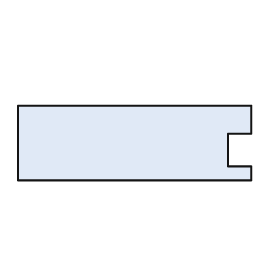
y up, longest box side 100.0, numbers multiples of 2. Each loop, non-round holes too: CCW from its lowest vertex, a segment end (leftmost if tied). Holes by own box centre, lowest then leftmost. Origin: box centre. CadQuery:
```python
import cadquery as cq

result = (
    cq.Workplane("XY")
    .moveTo(-50.0, -16.0)
    .lineTo(50.0, -16.0)
    .lineTo(50.0, -10.0)
    .lineTo(40.0, -10.0)
    .lineTo(40.0, 4.0)
    .lineTo(50.0, 4.0)
    .lineTo(50.0, 16.0)
    .lineTo(-50.0, 16.0)
    .close()
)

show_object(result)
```